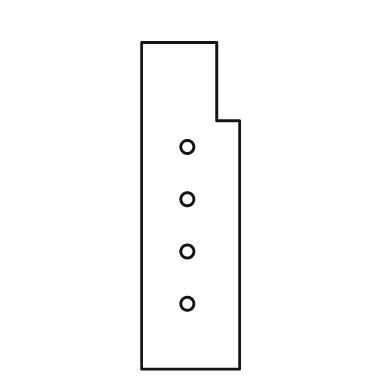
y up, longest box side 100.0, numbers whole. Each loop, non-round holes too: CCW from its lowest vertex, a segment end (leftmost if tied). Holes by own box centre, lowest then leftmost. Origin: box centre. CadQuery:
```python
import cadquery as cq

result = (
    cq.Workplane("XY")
    .moveTo(-15.0, -50.0)
    .lineTo(15.0, -50.0)
    .lineTo(15.0, 26.0)
    .lineTo(8.0, 26.0)
    .lineTo(8.0, 50.0)
    .lineTo(-15.0, 50.0)
    .close()
    .moveTo(-1.0, -30.0)
    .circle(2.0)
    .moveTo(-1.0, -14.0)
    .circle(2.0)
    .moveTo(-1.0, 2.0)
    .circle(2.0)
    .moveTo(-1.0, 18.0)
    .circle(2.0)
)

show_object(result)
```